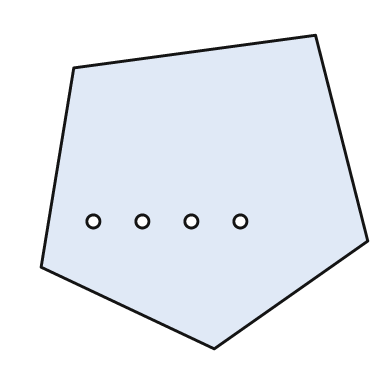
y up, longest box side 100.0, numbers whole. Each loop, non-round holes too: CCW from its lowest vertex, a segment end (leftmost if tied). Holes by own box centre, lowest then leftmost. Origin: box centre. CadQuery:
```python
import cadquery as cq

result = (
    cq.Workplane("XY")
    .moveTo(3.0, -48.0)
    .lineTo(50.0, -15.0)
    .lineTo(34.0, 48.0)
    .lineTo(-40.0, 38.0)
    .lineTo(-50.0, -23.0)
    .close()
    .moveTo(-34.0, -9.0)
    .circle(2.0)
    .moveTo(-19.0, -9.0)
    .circle(2.0)
    .moveTo(-4.0, -9.0)
    .circle(2.0)
    .moveTo(11.0, -9.0)
    .circle(2.0)
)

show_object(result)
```